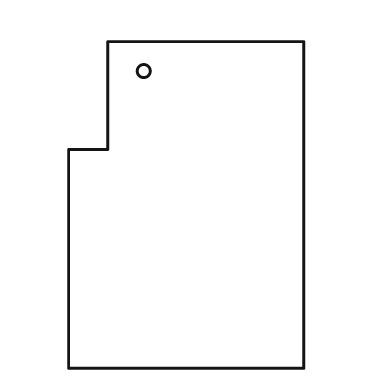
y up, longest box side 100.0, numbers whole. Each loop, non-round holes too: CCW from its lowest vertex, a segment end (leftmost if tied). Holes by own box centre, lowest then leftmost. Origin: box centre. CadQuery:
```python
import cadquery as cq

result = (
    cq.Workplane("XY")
    .moveTo(-36.0, -50.0)
    .lineTo(36.0, -50.0)
    .lineTo(36.0, 50.0)
    .lineTo(-24.0, 50.0)
    .lineTo(-24.0, 17.0)
    .lineTo(-36.0, 17.0)
    .close()
    .moveTo(-13.0, 41.0)
    .circle(2.0)
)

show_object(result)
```